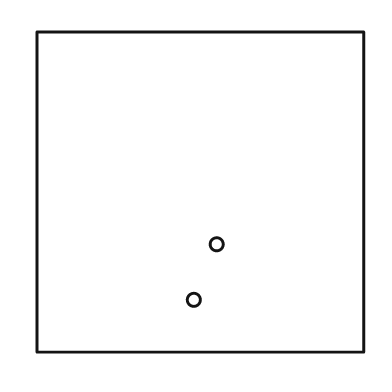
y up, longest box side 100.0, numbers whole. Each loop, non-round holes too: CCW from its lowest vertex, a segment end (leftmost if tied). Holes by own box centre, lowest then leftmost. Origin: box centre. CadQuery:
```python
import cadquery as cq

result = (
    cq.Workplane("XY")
    .moveTo(-50.0, -49.0)
    .lineTo(50.0, -49.0)
    .lineTo(50.0, 49.0)
    .lineTo(-50.0, 49.0)
    .close()
    .moveTo(-2.0, -33.0)
    .circle(2.0)
    .moveTo(5.0, -16.0)
    .circle(2.0)
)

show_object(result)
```